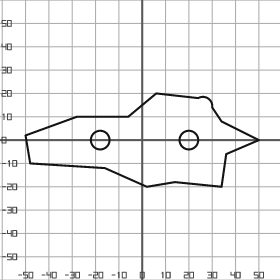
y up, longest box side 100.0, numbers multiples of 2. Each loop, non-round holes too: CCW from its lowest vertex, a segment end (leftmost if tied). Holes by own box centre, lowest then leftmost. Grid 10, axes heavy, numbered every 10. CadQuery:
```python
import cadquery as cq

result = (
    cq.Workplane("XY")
    .moveTo(2.0, -20.0)
    .lineTo(14.0, -18.0)
    .lineTo(34.0, -20.0)
    .lineTo(36.0, -6.0)
    .lineTo(50.0, 0.0)
    .lineTo(34.0, 8.0)
    .lineTo(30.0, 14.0)
    .threePointArc((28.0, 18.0), (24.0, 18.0))
    .lineTo(6.0, 20.0)
    .lineTo(-6.0, 10.0)
    .lineTo(-28.0, 10.0)
    .lineTo(-50.0, 2.0)
    .lineTo(-48.0, -10.0)
    .lineTo(-16.0, -12.0)
    .close()
    .moveTo(-18.0, 0.0)
    .circle(4.0)
    .moveTo(20.0, 0.0)
    .circle(4.0)
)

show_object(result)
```